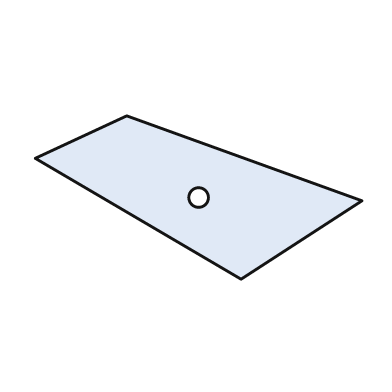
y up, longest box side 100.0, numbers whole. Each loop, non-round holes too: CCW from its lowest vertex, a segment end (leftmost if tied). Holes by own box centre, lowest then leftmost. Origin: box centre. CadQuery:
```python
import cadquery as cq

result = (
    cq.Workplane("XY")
    .moveTo(13.0, -25.0)
    .lineTo(50.0, -1.0)
    .lineTo(-22.0, 25.0)
    .lineTo(-50.0, 12.0)
    .close()
    .moveTo(0.0, 0.0)
    .circle(3.0)
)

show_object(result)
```